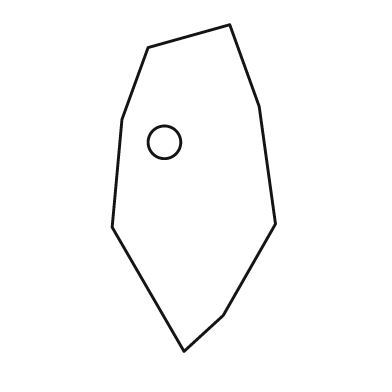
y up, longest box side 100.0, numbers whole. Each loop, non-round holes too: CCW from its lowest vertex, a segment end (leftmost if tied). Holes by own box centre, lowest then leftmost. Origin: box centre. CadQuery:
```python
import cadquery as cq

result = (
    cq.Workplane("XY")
    .moveTo(-3.0, -50.0)
    .lineTo(9.0, -39.0)
    .lineTo(25.0, -11.0)
    .lineTo(20.0, 25.0)
    .lineTo(11.0, 50.0)
    .lineTo(-14.0, 43.0)
    .lineTo(-22.0, 21.0)
    .lineTo(-25.0, -12.0)
    .close()
    .moveTo(-9.0, 14.0)
    .circle(5.0)
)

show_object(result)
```